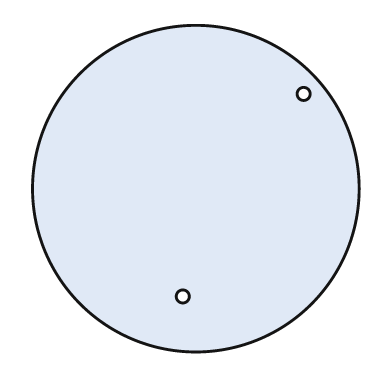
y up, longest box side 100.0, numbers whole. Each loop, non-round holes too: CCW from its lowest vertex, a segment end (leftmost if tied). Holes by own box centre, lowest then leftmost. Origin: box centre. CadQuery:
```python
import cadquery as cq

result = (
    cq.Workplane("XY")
    .moveTo(0.0, 0.0)
    .circle(50.0)
    .moveTo(-4.0, -33.0)
    .circle(2.0)
    .moveTo(33.0, 29.0)
    .circle(2.0)
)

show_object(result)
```